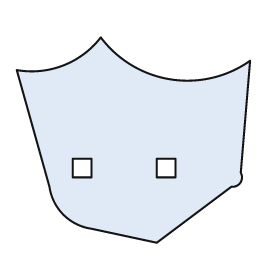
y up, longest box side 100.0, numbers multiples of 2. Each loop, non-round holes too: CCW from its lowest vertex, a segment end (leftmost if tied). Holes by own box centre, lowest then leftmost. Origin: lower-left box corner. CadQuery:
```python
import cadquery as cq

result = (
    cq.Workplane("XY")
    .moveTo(60.0, 0.0)
    .lineTo(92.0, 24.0)
    .threePointArc((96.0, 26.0), (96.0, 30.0))
    .lineTo(100.0, 78.0)
    .threePointArc((66.0, 70.0), (36.0, 88.0))
    .threePointArc((20.0, 76.0), (0.0, 74.0))
    .lineTo(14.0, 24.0)
    .threePointArc((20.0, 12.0), (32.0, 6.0))
    .close()
    .moveTo(24.0, 28.0)
    .lineTo(32.0, 28.0)
    .lineTo(32.0, 36.0)
    .lineTo(24.0, 36.0)
    .close()
    .moveTo(60.0, 28.0)
    .lineTo(68.0, 28.0)
    .lineTo(68.0, 36.0)
    .lineTo(60.0, 36.0)
    .close()
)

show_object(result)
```